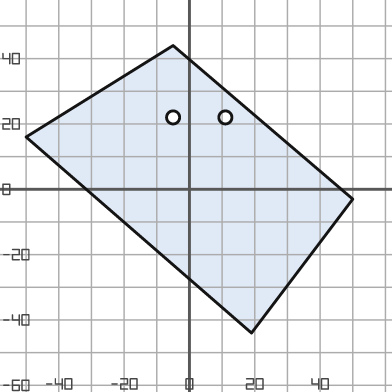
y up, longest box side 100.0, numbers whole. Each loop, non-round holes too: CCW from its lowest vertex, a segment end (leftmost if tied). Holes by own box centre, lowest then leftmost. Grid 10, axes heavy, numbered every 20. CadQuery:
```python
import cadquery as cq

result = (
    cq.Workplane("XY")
    .moveTo(19.0, -44.0)
    .lineTo(50.0, -3.0)
    .lineTo(-5.0, 44.0)
    .lineTo(-50.0, 16.0)
    .close()
    .moveTo(-5.0, 22.0)
    .circle(2.0)
    .moveTo(11.0, 22.0)
    .circle(2.0)
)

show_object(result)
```